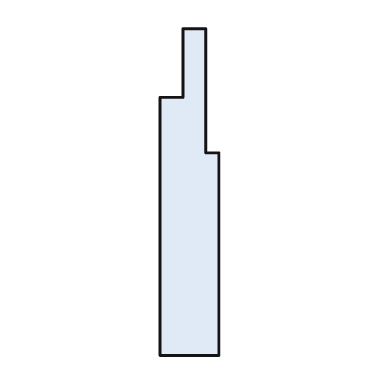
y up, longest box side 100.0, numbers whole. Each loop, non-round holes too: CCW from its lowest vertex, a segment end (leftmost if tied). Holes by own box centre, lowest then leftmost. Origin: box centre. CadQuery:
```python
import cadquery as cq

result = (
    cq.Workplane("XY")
    .moveTo(-9.0, -50.0)
    .lineTo(9.0, -50.0)
    .lineTo(9.0, 12.0)
    .lineTo(5.0, 12.0)
    .lineTo(5.0, 50.0)
    .lineTo(-2.0, 50.0)
    .lineTo(-2.0, 29.0)
    .lineTo(-9.0, 29.0)
    .close()
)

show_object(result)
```